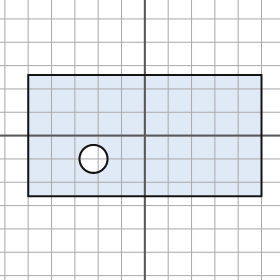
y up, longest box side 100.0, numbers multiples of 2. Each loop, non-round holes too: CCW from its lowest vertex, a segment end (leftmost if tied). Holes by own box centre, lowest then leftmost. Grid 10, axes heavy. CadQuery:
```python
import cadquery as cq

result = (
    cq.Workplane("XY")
    .moveTo(-50.0, -26.0)
    .lineTo(50.0, -26.0)
    .lineTo(50.0, 26.0)
    .lineTo(-50.0, 26.0)
    .close()
    .moveTo(-22.0, -10.0)
    .circle(6.0)
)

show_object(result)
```